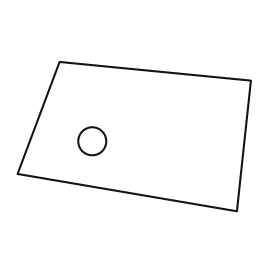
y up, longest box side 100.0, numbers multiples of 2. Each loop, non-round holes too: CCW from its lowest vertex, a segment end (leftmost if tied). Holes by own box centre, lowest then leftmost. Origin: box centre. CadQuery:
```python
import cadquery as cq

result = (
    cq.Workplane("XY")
    .moveTo(44.0, -32.0)
    .lineTo(50.0, 24.0)
    .lineTo(-32.0, 32.0)
    .lineTo(-50.0, -16.0)
    .close()
    .moveTo(-18.0, -2.0)
    .circle(6.0)
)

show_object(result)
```